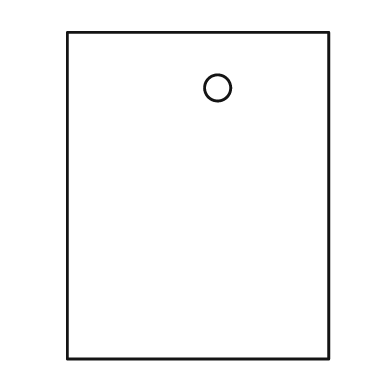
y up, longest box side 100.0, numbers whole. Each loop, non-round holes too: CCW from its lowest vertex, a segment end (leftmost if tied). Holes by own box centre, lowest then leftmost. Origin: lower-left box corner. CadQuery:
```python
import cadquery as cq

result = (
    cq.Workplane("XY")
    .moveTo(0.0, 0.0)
    .lineTo(80.0, 0.0)
    .lineTo(80.0, 100.0)
    .lineTo(0.0, 100.0)
    .close()
    .moveTo(46.0, 83.0)
    .circle(4.0)
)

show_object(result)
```